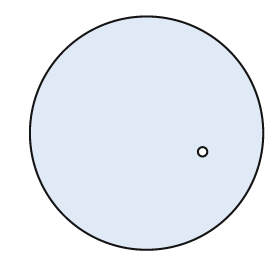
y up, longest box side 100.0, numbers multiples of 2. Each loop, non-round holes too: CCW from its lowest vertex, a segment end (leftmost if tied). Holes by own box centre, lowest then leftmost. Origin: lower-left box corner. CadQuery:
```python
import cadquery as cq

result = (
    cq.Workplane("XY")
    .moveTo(50.0, 50.0)
    .circle(50.0)
    .moveTo(74.0, 42.0)
    .circle(2.0)
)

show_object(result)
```